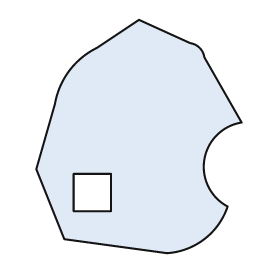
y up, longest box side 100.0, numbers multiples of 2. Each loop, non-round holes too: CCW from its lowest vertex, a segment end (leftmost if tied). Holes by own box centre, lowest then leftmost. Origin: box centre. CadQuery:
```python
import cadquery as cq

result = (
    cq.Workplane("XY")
    .moveTo(12.0, -50.0)
    .threePointArc((28.0, -44.0), (38.0, -30.0))
    .threePointArc((28.0, -10.0), (44.0, 6.0))
    .lineTo(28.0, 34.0)
    .threePointArc((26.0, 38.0), (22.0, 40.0))
    .lineTo(0.0, 50.0)
    .lineTo(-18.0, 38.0)
    .threePointArc((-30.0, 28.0), (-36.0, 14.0))
    .lineTo(-44.0, -14.0)
    .lineTo(-32.0, -44.0)
    .close()
    .moveTo(-28.0, -32.0)
    .lineTo(-12.0, -32.0)
    .lineTo(-12.0, -16.0)
    .lineTo(-28.0, -16.0)
    .close()
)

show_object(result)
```